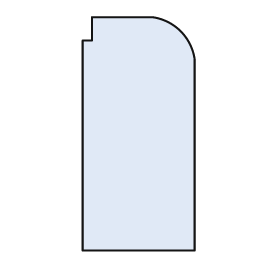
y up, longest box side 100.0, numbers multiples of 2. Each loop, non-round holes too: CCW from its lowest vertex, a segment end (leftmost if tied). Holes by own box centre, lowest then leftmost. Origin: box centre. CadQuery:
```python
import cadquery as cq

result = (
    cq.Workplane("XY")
    .moveTo(-24.0, -50.0)
    .lineTo(24.0, -50.0)
    .lineTo(24.0, 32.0)
    .threePointArc((18.0, 44.0), (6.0, 50.0))
    .lineTo(-20.0, 50.0)
    .lineTo(-20.0, 40.0)
    .lineTo(-24.0, 40.0)
    .close()
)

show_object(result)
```